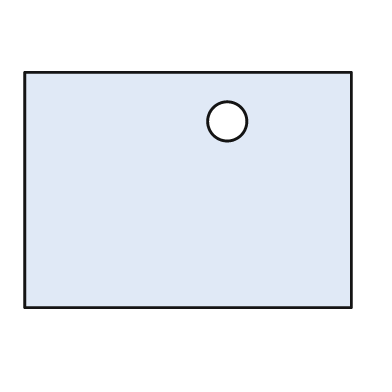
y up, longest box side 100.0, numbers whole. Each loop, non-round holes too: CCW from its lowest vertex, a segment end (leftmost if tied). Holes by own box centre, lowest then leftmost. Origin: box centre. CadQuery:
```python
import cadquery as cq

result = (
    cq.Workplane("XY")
    .moveTo(-50.0, -36.0)
    .lineTo(50.0, -36.0)
    .lineTo(50.0, 36.0)
    .lineTo(-50.0, 36.0)
    .close()
    .moveTo(12.0, 21.0)
    .circle(6.0)
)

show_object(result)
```